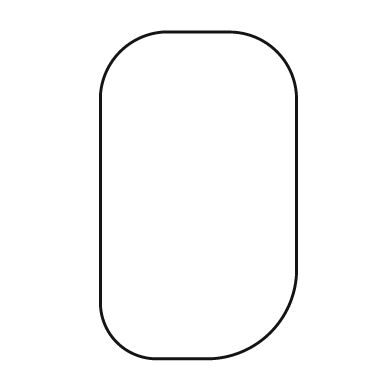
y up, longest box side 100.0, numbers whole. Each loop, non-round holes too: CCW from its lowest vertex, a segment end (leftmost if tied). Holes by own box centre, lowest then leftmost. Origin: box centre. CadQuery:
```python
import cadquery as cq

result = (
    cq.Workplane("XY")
    .moveTo(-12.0, -50.0)
    .lineTo(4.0, -50.0)
    .threePointArc((22.0, -42.0), (30.0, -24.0))
    .lineTo(30.0, 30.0)
    .threePointArc((24.0, 44.0), (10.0, 50.0))
    .lineTo(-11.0, 50.0)
    .threePointArc((-24.0, 44.0), (-30.0, 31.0))
    .lineTo(-30.0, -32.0)
    .threePointArc((-25.0, -45.0), (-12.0, -50.0))
    .close()
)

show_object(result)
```